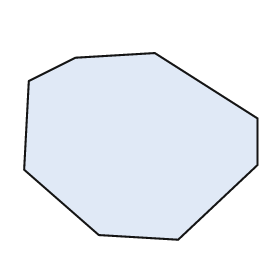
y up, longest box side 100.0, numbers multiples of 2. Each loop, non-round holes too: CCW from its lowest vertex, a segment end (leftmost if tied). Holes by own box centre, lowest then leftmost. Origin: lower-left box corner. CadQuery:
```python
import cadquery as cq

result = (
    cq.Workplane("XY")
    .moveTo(66.0, 0.0)
    .lineTo(100.0, 32.0)
    .lineTo(100.0, 52.0)
    .lineTo(56.0, 80.0)
    .lineTo(22.0, 78.0)
    .lineTo(2.0, 68.0)
    .lineTo(0.0, 30.0)
    .lineTo(32.0, 2.0)
    .close()
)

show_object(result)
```